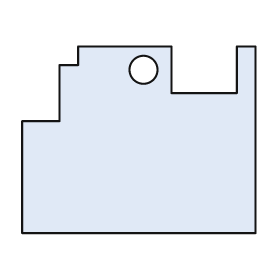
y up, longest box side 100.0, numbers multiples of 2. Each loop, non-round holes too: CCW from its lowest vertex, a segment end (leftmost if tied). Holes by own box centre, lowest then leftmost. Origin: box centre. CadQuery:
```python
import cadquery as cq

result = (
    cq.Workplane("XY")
    .moveTo(-50.0, -40.0)
    .lineTo(50.0, -40.0)
    .lineTo(50.0, 40.0)
    .lineTo(42.0, 40.0)
    .lineTo(42.0, 20.0)
    .lineTo(14.0, 20.0)
    .lineTo(14.0, 40.0)
    .lineTo(-26.0, 40.0)
    .lineTo(-26.0, 32.0)
    .lineTo(-34.0, 32.0)
    .lineTo(-34.0, 8.0)
    .lineTo(-50.0, 8.0)
    .close()
    .moveTo(2.0, 30.0)
    .circle(6.0)
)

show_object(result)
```